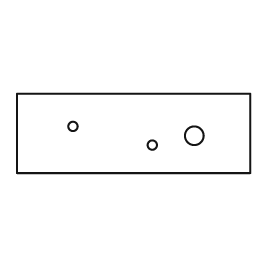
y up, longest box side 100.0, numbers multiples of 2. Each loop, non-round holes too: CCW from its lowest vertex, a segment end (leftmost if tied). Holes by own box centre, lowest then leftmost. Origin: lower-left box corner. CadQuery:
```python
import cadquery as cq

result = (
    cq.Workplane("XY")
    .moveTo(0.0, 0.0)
    .lineTo(100.0, 0.0)
    .lineTo(100.0, 34.0)
    .lineTo(0.0, 34.0)
    .close()
    .moveTo(58.0, 12.0)
    .circle(2.0)
    .moveTo(76.0, 16.0)
    .circle(4.0)
    .moveTo(24.0, 20.0)
    .circle(2.0)
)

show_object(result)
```